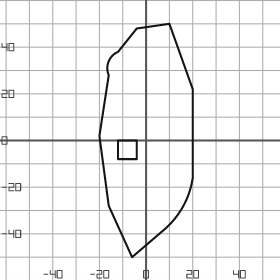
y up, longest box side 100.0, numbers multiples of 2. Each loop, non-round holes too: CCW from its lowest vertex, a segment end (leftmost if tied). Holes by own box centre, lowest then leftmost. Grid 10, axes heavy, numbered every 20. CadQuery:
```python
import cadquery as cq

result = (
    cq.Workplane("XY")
    .moveTo(-6.0, -50.0)
    .lineTo(8.0, -38.0)
    .threePointArc((16.0, -28.0), (20.0, -16.0))
    .lineTo(20.0, 22.0)
    .lineTo(10.0, 50.0)
    .lineTo(-4.0, 48.0)
    .lineTo(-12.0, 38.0)
    .threePointArc((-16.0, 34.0), (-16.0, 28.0))
    .lineTo(-20.0, 2.0)
    .lineTo(-16.0, -28.0)
    .close()
    .moveTo(-12.0, -8.0)
    .lineTo(-4.0, -8.0)
    .lineTo(-4.0, 0.0)
    .lineTo(-12.0, 0.0)
    .close()
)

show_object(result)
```